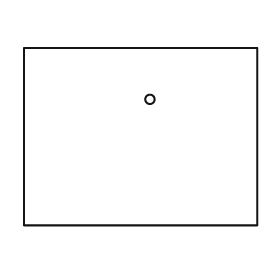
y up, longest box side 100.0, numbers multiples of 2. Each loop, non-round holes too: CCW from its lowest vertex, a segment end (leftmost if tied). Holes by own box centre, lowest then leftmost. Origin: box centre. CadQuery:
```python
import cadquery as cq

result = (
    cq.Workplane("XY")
    .moveTo(-50.0, -38.0)
    .lineTo(50.0, -38.0)
    .lineTo(50.0, 38.0)
    .lineTo(-50.0, 38.0)
    .close()
    .moveTo(4.0, 16.0)
    .circle(2.0)
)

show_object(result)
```